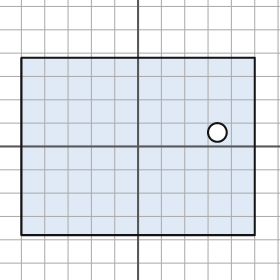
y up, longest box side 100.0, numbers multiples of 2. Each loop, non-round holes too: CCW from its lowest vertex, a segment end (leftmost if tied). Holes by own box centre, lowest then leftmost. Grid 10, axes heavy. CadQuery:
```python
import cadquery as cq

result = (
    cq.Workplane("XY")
    .moveTo(-50.0, -38.0)
    .lineTo(50.0, -38.0)
    .lineTo(50.0, 38.0)
    .lineTo(-50.0, 38.0)
    .close()
    .moveTo(34.0, 6.0)
    .circle(4.0)
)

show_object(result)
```